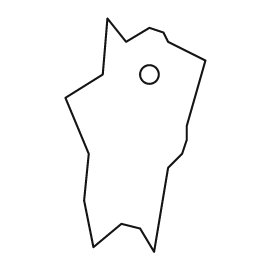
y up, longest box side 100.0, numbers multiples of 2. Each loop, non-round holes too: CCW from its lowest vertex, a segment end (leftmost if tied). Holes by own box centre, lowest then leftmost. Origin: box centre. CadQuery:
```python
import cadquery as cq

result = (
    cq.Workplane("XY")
    .moveTo(8.0, -50.0)
    .lineTo(14.0, -14.0)
    .lineTo(20.0, -8.0)
    .lineTo(22.0, -2.0)
    .lineTo(22.0, 4.0)
    .lineTo(30.0, 32.0)
    .lineTo(14.0, 40.0)
    .lineTo(12.0, 44.0)
    .lineTo(6.0, 46.0)
    .lineTo(-4.0, 40.0)
    .lineTo(-12.0, 50.0)
    .lineTo(-14.0, 26.0)
    .lineTo(-30.0, 16.0)
    .lineTo(-20.0, -8.0)
    .lineTo(-22.0, -28.0)
    .lineTo(-18.0, -48.0)
    .lineTo(-6.0, -38.0)
    .lineTo(2.0, -40.0)
    .close()
    .moveTo(6.0, 26.0)
    .circle(4.0)
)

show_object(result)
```